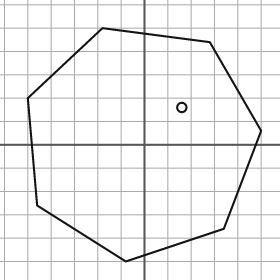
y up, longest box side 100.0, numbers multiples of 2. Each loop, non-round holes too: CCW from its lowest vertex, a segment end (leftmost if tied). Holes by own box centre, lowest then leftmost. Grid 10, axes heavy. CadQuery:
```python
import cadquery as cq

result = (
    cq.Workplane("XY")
    .moveTo(-8.0, -50.0)
    .lineTo(34.0, -36.0)
    .lineTo(50.0, 6.0)
    .lineTo(28.0, 44.0)
    .lineTo(-18.0, 50.0)
    .lineTo(-50.0, 20.0)
    .lineTo(-46.0, -26.0)
    .close()
    .moveTo(16.0, 16.0)
    .circle(2.0)
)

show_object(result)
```